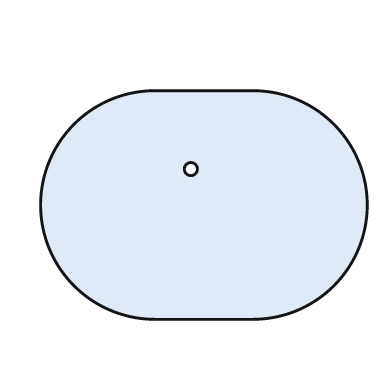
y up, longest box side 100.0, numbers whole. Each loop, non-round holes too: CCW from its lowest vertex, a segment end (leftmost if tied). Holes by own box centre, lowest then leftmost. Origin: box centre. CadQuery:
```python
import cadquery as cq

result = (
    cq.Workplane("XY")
    .moveTo(-15.0, -35.0)
    .lineTo(15.0, -35.0)
    .threePointArc((50.0, 0.0), (15.0, 35.0))
    .lineTo(-15.0, 35.0)
    .threePointArc((-50.0, 0.0), (-15.0, -35.0))
    .close()
    .moveTo(-4.0, 11.0)
    .circle(2.0)
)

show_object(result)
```